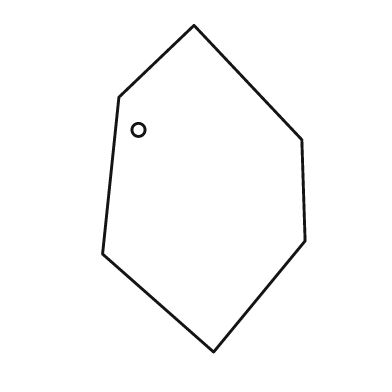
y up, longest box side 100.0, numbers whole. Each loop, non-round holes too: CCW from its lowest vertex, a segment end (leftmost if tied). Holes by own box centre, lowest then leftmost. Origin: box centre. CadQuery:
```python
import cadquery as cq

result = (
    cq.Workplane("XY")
    .moveTo(3.0, -50.0)
    .lineTo(31.0, -16.0)
    .lineTo(30.0, 15.0)
    .lineTo(-3.0, 50.0)
    .lineTo(-26.0, 28.0)
    .lineTo(-31.0, -20.0)
    .close()
    .moveTo(-20.0, 18.0)
    .circle(2.0)
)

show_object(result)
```